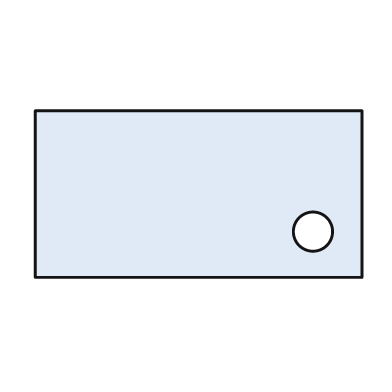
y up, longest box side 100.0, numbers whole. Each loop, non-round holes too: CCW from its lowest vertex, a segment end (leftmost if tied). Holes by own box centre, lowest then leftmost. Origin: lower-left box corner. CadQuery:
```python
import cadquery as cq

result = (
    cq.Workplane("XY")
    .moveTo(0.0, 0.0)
    .lineTo(100.0, 0.0)
    .lineTo(100.0, 51.0)
    .lineTo(0.0, 51.0)
    .close()
    .moveTo(85.0, 14.0)
    .circle(6.0)
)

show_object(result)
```